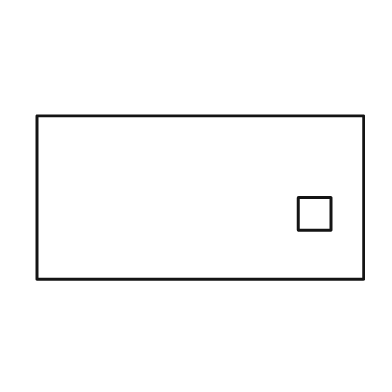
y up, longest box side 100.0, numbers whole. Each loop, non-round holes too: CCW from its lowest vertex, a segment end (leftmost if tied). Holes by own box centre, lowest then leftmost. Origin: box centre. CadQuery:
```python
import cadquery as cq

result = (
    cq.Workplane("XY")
    .moveTo(-50.0, -25.0)
    .lineTo(50.0, -25.0)
    .lineTo(50.0, 25.0)
    .lineTo(-50.0, 25.0)
    .close()
    .moveTo(30.0, -10.0)
    .lineTo(40.0, -10.0)
    .lineTo(40.0, 0.0)
    .lineTo(30.0, 0.0)
    .close()
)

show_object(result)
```